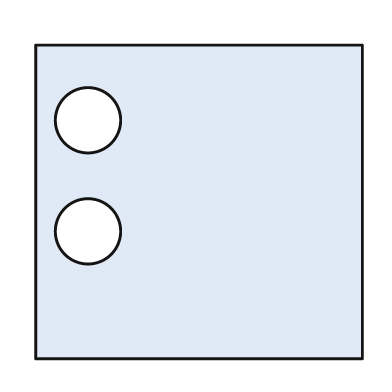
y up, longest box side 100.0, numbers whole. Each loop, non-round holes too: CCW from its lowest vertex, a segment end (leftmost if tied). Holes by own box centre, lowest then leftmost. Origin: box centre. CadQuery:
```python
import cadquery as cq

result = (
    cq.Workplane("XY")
    .moveTo(-50.0, -48.0)
    .lineTo(50.0, -48.0)
    .lineTo(50.0, 48.0)
    .lineTo(-50.0, 48.0)
    .close()
    .moveTo(-34.0, -9.0)
    .circle(10.0)
    .moveTo(-34.0, 25.0)
    .circle(10.0)
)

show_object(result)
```